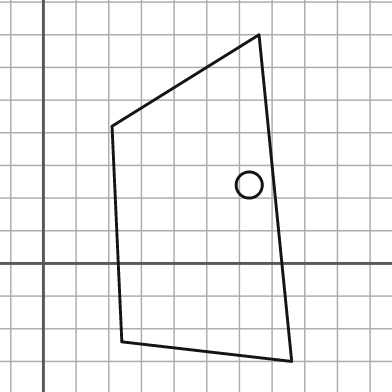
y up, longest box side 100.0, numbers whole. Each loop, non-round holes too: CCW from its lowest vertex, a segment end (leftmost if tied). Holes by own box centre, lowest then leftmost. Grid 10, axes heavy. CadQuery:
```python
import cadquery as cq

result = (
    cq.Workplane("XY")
    .moveTo(76.0, -30.0)
    .lineTo(66.0, 70.0)
    .lineTo(21.0, 42.0)
    .lineTo(24.0, -24.0)
    .close()
    .moveTo(63.0, 24.0)
    .circle(4.0)
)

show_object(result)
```